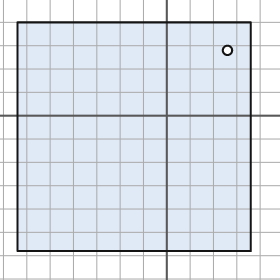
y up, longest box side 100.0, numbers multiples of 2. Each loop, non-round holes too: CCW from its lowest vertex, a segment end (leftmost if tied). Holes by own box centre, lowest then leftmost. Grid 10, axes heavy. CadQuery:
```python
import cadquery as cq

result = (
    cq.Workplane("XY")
    .moveTo(-64.0, -58.0)
    .lineTo(36.0, -58.0)
    .lineTo(36.0, 40.0)
    .lineTo(-64.0, 40.0)
    .close()
    .moveTo(26.0, 28.0)
    .circle(2.0)
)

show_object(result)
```